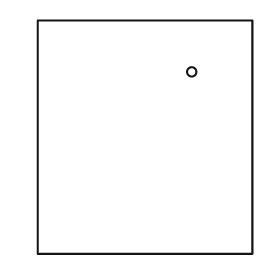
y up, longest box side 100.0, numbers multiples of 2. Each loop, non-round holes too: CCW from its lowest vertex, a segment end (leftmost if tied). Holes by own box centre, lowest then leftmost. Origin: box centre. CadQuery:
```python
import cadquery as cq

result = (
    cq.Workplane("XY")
    .moveTo(-46.0, -50.0)
    .lineTo(46.0, -50.0)
    .lineTo(46.0, 50.0)
    .lineTo(-46.0, 50.0)
    .close()
    .moveTo(20.0, 28.0)
    .circle(2.0)
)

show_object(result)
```